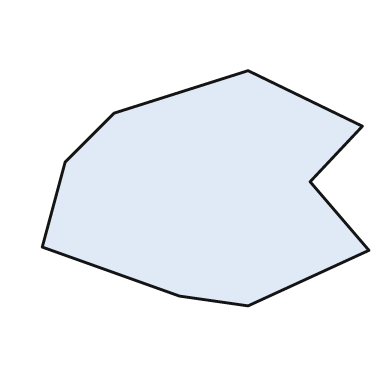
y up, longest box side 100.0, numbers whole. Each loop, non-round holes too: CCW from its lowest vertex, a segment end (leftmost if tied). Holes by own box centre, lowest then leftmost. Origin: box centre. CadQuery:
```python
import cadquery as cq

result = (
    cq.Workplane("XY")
    .moveTo(13.0, -36.0)
    .lineTo(50.0, -19.0)
    .lineTo(32.0, 2.0)
    .lineTo(48.0, 19.0)
    .lineTo(13.0, 36.0)
    .lineTo(-28.0, 23.0)
    .lineTo(-43.0, 8.0)
    .lineTo(-50.0, -18.0)
    .lineTo(-8.0, -33.0)
    .close()
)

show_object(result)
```